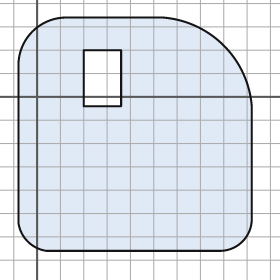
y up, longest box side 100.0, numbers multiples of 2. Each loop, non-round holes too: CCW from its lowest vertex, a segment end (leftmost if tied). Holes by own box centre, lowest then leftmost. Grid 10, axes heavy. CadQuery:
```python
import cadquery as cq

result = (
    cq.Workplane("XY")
    .moveTo(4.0, -66.0)
    .lineTo(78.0, -66.0)
    .threePointArc((88.0, -62.0), (92.0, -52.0))
    .lineTo(92.0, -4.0)
    .threePointArc((80.0, 22.0), (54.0, 34.0))
    .lineTo(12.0, 34.0)
    .threePointArc((-2.0, 28.0), (-8.0, 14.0))
    .lineTo(-8.0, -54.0)
    .threePointArc((-4.0, -62.0), (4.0, -66.0))
    .close()
    .moveTo(20.0, -4.0)
    .lineTo(36.0, -4.0)
    .lineTo(36.0, 20.0)
    .lineTo(20.0, 20.0)
    .close()
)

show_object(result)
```